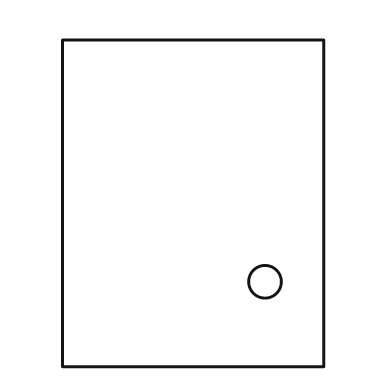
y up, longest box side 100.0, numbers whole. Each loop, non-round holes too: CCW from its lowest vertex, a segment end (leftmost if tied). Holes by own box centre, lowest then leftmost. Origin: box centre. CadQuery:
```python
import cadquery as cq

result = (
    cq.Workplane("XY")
    .moveTo(-40.0, -50.0)
    .lineTo(40.0, -50.0)
    .lineTo(40.0, 50.0)
    .lineTo(-40.0, 50.0)
    .close()
    .moveTo(22.0, -24.0)
    .circle(5.0)
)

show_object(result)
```